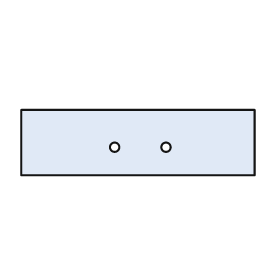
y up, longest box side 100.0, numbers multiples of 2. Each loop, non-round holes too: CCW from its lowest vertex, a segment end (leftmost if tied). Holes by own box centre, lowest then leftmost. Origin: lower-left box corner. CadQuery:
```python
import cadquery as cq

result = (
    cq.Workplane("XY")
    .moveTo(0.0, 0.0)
    .lineTo(100.0, 0.0)
    .lineTo(100.0, 28.0)
    .lineTo(0.0, 28.0)
    .close()
    .moveTo(40.0, 12.0)
    .circle(2.0)
    .moveTo(62.0, 12.0)
    .circle(2.0)
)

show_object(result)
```